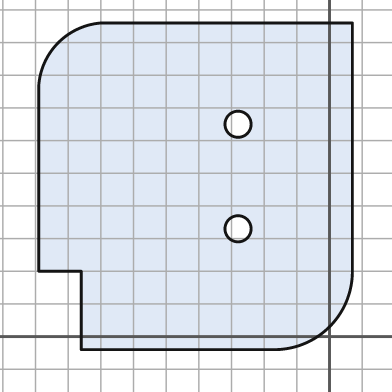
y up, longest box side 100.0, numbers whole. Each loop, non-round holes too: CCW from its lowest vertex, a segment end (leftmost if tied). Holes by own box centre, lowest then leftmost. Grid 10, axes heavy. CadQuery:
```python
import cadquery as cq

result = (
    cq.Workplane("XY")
    .moveTo(-76.0, -4.0)
    .lineTo(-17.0, -4.0)
    .threePointArc((0.0, 3.0), (7.0, 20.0))
    .lineTo(7.0, 96.0)
    .lineTo(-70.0, 96.0)
    .threePointArc((-83.0, 90.0), (-89.0, 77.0))
    .lineTo(-89.0, 20.0)
    .lineTo(-76.0, 20.0)
    .close()
    .moveTo(-28.0, 33.0)
    .circle(4.0)
    .moveTo(-28.0, 65.0)
    .circle(4.0)
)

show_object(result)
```